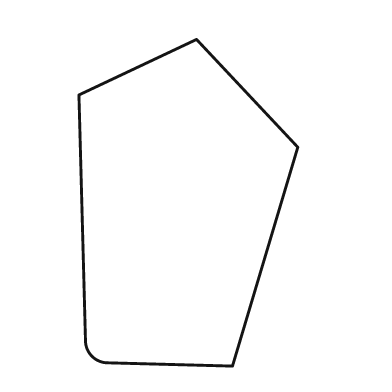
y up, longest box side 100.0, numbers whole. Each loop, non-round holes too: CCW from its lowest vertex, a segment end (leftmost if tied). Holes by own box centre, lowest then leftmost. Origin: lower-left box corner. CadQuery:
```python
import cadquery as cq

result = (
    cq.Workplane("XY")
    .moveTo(47.0, 0.0)
    .lineTo(67.0, 67.0)
    .lineTo(36.0, 100.0)
    .lineTo(0.0, 83.0)
    .lineTo(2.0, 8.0)
    .threePointArc((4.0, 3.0), (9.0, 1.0))
    .close()
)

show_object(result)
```